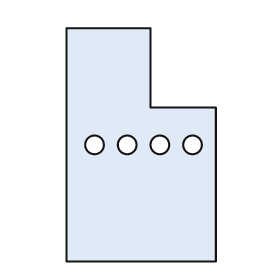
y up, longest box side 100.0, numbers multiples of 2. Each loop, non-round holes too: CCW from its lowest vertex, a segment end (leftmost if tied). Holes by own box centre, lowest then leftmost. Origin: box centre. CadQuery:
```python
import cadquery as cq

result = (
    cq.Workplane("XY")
    .moveTo(-32.0, -50.0)
    .lineTo(32.0, -50.0)
    .lineTo(32.0, 16.0)
    .lineTo(4.0, 16.0)
    .lineTo(4.0, 50.0)
    .lineTo(-32.0, 50.0)
    .close()
    .moveTo(-20.0, 0.0)
    .circle(4.0)
    .moveTo(-6.0, 0.0)
    .circle(4.0)
    .moveTo(8.0, 0.0)
    .circle(4.0)
    .moveTo(22.0, 0.0)
    .circle(4.0)
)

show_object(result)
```